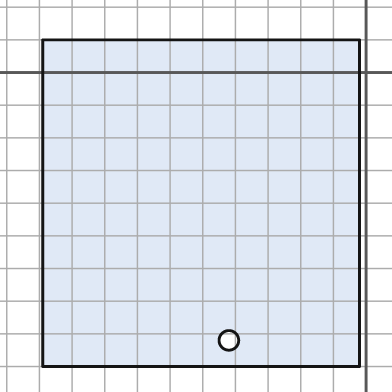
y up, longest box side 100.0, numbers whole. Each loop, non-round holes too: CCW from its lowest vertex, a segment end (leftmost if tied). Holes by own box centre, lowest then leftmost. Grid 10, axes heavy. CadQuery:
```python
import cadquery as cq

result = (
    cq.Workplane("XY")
    .moveTo(-99.0, -90.0)
    .lineTo(-2.0, -90.0)
    .lineTo(-2.0, 10.0)
    .lineTo(-99.0, 10.0)
    .close()
    .moveTo(-42.0, -82.0)
    .circle(3.0)
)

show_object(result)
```